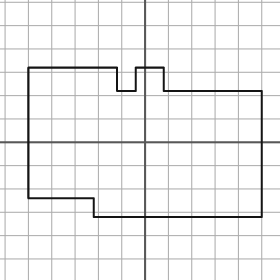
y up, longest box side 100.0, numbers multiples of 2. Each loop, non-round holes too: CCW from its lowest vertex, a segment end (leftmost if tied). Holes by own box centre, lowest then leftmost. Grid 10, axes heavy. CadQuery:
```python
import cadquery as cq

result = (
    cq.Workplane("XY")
    .moveTo(-22.0, -32.0)
    .lineTo(50.0, -32.0)
    .lineTo(50.0, 22.0)
    .lineTo(8.0, 22.0)
    .lineTo(8.0, 32.0)
    .lineTo(-4.0, 32.0)
    .lineTo(-4.0, 22.0)
    .lineTo(-12.0, 22.0)
    .lineTo(-12.0, 32.0)
    .lineTo(-50.0, 32.0)
    .lineTo(-50.0, -24.0)
    .lineTo(-22.0, -24.0)
    .close()
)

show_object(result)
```